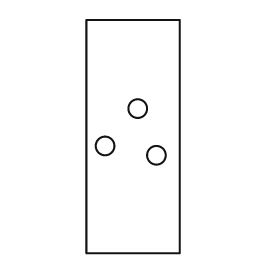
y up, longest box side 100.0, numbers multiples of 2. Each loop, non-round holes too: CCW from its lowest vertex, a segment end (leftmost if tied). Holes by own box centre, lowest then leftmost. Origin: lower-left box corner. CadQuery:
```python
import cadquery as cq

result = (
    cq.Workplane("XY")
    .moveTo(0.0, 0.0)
    .lineTo(40.0, 0.0)
    .lineTo(40.0, 100.0)
    .lineTo(0.0, 100.0)
    .close()
    .moveTo(30.0, 42.0)
    .circle(4.0)
    .moveTo(8.0, 46.0)
    .circle(4.0)
    .moveTo(22.0, 62.0)
    .circle(4.0)
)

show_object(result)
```